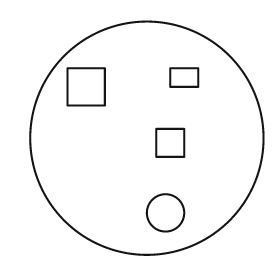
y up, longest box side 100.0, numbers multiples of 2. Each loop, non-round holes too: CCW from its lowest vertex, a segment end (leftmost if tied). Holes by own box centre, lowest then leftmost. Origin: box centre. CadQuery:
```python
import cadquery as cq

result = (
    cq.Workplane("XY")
    .moveTo(0.0, 0.0)
    .circle(50.0)
    .moveTo(8.0, -32.0)
    .circle(8.0)
    .moveTo(4.0, -8.0)
    .lineTo(16.0, -8.0)
    .lineTo(16.0, 4.0)
    .lineTo(4.0, 4.0)
    .close()
    .moveTo(-34.0, 14.0)
    .lineTo(-18.0, 14.0)
    .lineTo(-18.0, 30.0)
    .lineTo(-34.0, 30.0)
    .close()
    .moveTo(10.0, 22.0)
    .lineTo(22.0, 22.0)
    .lineTo(22.0, 30.0)
    .lineTo(10.0, 30.0)
    .close()
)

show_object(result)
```